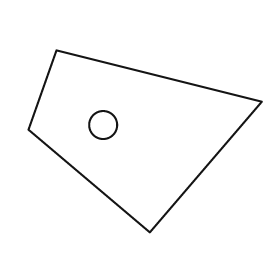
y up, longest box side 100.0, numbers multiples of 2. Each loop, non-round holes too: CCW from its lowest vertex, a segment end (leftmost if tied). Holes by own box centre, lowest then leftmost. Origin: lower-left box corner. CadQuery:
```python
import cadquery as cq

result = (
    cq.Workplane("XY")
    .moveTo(52.0, 0.0)
    .lineTo(100.0, 56.0)
    .lineTo(12.0, 78.0)
    .lineTo(0.0, 44.0)
    .close()
    .moveTo(32.0, 46.0)
    .circle(6.0)
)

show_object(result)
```